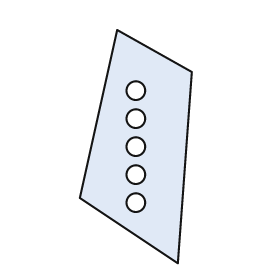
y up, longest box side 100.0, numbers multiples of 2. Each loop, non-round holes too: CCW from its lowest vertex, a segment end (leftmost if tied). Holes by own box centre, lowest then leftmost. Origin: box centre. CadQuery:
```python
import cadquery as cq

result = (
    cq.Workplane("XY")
    .moveTo(18.0, -50.0)
    .lineTo(24.0, 32.0)
    .lineTo(-8.0, 50.0)
    .lineTo(-24.0, -22.0)
    .close()
    .moveTo(0.0, -24.0)
    .circle(4.0)
    .moveTo(0.0, -12.0)
    .circle(4.0)
    .moveTo(0.0, 0.0)
    .circle(4.0)
    .moveTo(0.0, 12.0)
    .circle(4.0)
    .moveTo(0.0, 24.0)
    .circle(4.0)
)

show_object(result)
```